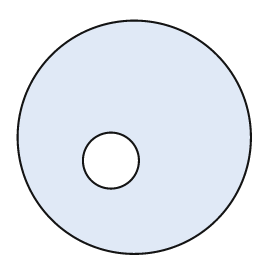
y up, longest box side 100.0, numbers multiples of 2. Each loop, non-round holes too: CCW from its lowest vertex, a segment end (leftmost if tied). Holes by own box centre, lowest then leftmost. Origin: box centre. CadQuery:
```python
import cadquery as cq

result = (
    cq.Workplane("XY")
    .moveTo(0.0, 0.0)
    .circle(50.0)
    .moveTo(-10.0, -10.0)
    .circle(12.0)
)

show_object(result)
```